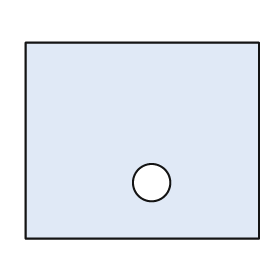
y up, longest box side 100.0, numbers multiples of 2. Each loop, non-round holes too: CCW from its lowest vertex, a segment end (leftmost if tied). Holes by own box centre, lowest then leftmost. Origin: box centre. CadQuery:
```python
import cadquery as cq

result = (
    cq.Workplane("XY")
    .moveTo(-50.0, -42.0)
    .lineTo(50.0, -42.0)
    .lineTo(50.0, 42.0)
    .lineTo(-50.0, 42.0)
    .close()
    .moveTo(4.0, -18.0)
    .circle(8.0)
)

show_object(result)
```